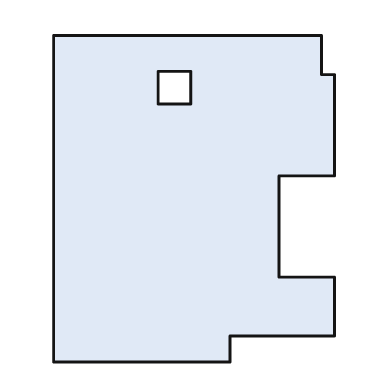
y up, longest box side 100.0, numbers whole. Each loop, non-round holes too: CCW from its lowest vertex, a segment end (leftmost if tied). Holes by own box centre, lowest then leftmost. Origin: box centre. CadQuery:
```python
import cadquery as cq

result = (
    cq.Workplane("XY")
    .moveTo(-43.0, -50.0)
    .lineTo(11.0, -50.0)
    .lineTo(11.0, -42.0)
    .lineTo(43.0, -42.0)
    .lineTo(43.0, -24.0)
    .lineTo(26.0, -24.0)
    .lineTo(26.0, 7.0)
    .lineTo(43.0, 7.0)
    .lineTo(43.0, 38.0)
    .lineTo(39.0, 38.0)
    .lineTo(39.0, 50.0)
    .lineTo(-43.0, 50.0)
    .close()
    .moveTo(-11.0, 29.0)
    .lineTo(-1.0, 29.0)
    .lineTo(-1.0, 39.0)
    .lineTo(-11.0, 39.0)
    .close()
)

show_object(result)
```